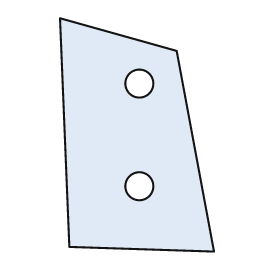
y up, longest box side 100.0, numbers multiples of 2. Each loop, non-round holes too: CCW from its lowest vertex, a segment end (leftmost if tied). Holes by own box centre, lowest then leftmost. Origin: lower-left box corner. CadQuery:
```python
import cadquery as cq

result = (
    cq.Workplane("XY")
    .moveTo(66.0, 0.0)
    .lineTo(50.0, 86.0)
    .lineTo(0.0, 100.0)
    .lineTo(4.0, 2.0)
    .close()
    .moveTo(34.0, 28.0)
    .circle(6.0)
    .moveTo(34.0, 72.0)
    .circle(6.0)
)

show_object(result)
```